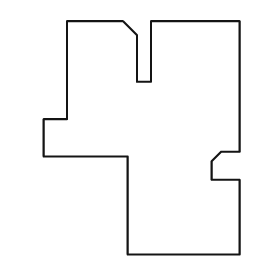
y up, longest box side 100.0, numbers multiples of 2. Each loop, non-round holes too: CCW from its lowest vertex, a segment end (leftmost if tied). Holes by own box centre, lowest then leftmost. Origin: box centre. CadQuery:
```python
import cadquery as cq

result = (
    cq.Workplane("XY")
    .moveTo(-6.0, -50.0)
    .lineTo(42.0, -50.0)
    .lineTo(42.0, -18.0)
    .lineTo(30.0, -18.0)
    .lineTo(30.0, -10.0)
    .lineTo(34.0, -6.0)
    .lineTo(42.0, -6.0)
    .lineTo(42.0, 50.0)
    .lineTo(4.0, 50.0)
    .lineTo(4.0, 24.0)
    .lineTo(-2.0, 24.0)
    .lineTo(-2.0, 44.0)
    .lineTo(-8.0, 50.0)
    .lineTo(-32.0, 50.0)
    .lineTo(-32.0, 8.0)
    .lineTo(-42.0, 8.0)
    .lineTo(-42.0, -8.0)
    .lineTo(-6.0, -8.0)
    .close()
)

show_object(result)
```